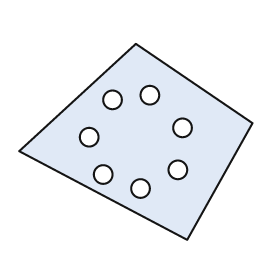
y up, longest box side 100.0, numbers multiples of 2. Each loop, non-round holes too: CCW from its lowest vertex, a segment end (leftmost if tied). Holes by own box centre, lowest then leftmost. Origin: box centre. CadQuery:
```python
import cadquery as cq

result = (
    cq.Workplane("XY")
    .moveTo(22.0, -42.0)
    .lineTo(50.0, 8.0)
    .lineTo(0.0, 42.0)
    .lineTo(-50.0, -4.0)
    .close()
    .moveTo(2.0, -20.0)
    .circle(4.0)
    .moveTo(-14.0, -14.0)
    .circle(4.0)
    .moveTo(18.0, -12.0)
    .circle(4.0)
    .moveTo(-20.0, 2.0)
    .circle(4.0)
    .moveTo(20.0, 6.0)
    .circle(4.0)
    .moveTo(-10.0, 18.0)
    .circle(4.0)
    .moveTo(6.0, 20.0)
    .circle(4.0)
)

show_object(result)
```